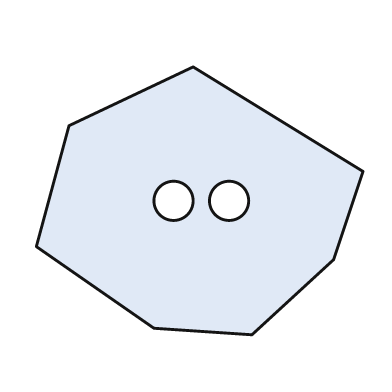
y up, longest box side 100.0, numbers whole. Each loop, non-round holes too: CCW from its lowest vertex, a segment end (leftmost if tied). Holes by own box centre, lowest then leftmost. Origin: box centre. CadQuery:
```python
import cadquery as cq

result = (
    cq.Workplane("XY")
    .moveTo(16.0, -41.0)
    .lineTo(41.0, -18.0)
    .lineTo(50.0, 9.0)
    .lineTo(-2.0, 41.0)
    .lineTo(-40.0, 23.0)
    .lineTo(-50.0, -14.0)
    .lineTo(-14.0, -39.0)
    .close()
    .moveTo(-8.0, 0.0)
    .circle(6.0)
    .moveTo(9.0, 0.0)
    .circle(6.0)
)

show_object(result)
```